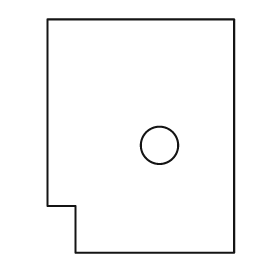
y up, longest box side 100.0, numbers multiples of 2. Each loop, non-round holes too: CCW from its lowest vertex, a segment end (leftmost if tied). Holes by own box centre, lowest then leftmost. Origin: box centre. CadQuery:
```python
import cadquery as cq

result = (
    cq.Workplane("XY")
    .moveTo(-28.0, -50.0)
    .lineTo(40.0, -50.0)
    .lineTo(40.0, 50.0)
    .lineTo(-40.0, 50.0)
    .lineTo(-40.0, -30.0)
    .lineTo(-28.0, -30.0)
    .close()
    .moveTo(8.0, -4.0)
    .circle(8.0)
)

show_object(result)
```